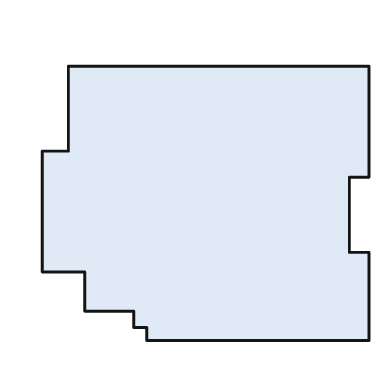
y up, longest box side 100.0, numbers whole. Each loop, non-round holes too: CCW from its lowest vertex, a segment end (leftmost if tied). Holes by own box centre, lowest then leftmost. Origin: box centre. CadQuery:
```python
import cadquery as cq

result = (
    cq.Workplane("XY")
    .moveTo(-18.0, -42.0)
    .lineTo(50.0, -42.0)
    .lineTo(50.0, -15.0)
    .lineTo(44.0, -15.0)
    .lineTo(44.0, 8.0)
    .lineTo(50.0, 8.0)
    .lineTo(50.0, 42.0)
    .lineTo(-42.0, 42.0)
    .lineTo(-42.0, 16.0)
    .lineTo(-50.0, 16.0)
    .lineTo(-50.0, -21.0)
    .lineTo(-37.0, -21.0)
    .lineTo(-37.0, -33.0)
    .lineTo(-22.0, -33.0)
    .lineTo(-22.0, -38.0)
    .lineTo(-18.0, -38.0)
    .close()
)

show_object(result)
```